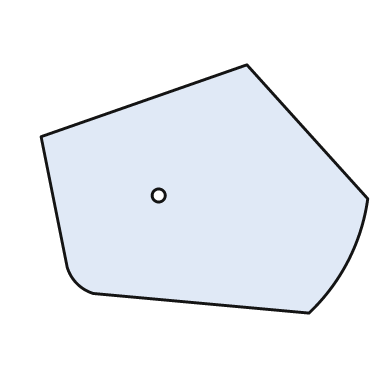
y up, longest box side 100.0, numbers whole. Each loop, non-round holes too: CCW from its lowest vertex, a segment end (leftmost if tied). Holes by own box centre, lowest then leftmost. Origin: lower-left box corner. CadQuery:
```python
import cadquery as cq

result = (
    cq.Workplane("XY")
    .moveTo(82.0, 0.0)
    .threePointArc((94.0, 16.0), (100.0, 35.0))
    .lineTo(63.0, 76.0)
    .lineTo(0.0, 54.0)
    .lineTo(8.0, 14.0)
    .threePointArc((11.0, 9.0), (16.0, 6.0))
    .close()
    .moveTo(36.0, 36.0)
    .circle(2.0)
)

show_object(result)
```